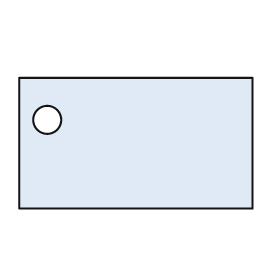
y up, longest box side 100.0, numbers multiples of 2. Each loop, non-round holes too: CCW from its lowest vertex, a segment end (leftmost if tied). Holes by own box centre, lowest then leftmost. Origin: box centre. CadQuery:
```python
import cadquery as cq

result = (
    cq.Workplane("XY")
    .moveTo(-50.0, -28.0)
    .lineTo(50.0, -28.0)
    .lineTo(50.0, 28.0)
    .lineTo(-50.0, 28.0)
    .close()
    .moveTo(-38.0, 10.0)
    .circle(6.0)
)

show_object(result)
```